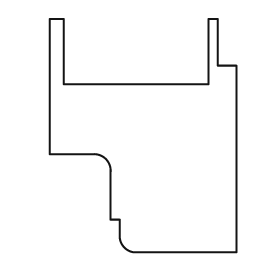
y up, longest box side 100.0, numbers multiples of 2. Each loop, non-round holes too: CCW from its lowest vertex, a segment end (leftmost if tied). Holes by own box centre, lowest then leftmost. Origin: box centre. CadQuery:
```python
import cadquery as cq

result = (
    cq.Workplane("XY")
    .moveTo(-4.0, -50.0)
    .lineTo(40.0, -50.0)
    .lineTo(40.0, 30.0)
    .lineTo(32.0, 30.0)
    .lineTo(32.0, 50.0)
    .lineTo(28.0, 50.0)
    .lineTo(28.0, 22.0)
    .lineTo(-34.0, 22.0)
    .lineTo(-34.0, 50.0)
    .lineTo(-40.0, 50.0)
    .lineTo(-40.0, -8.0)
    .lineTo(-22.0, -8.0)
    .threePointArc((-16.0, -10.0), (-14.0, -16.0))
    .lineTo(-14.0, -36.0)
    .lineTo(-10.0, -36.0)
    .lineTo(-10.0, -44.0)
    .threePointArc((-8.0, -48.0), (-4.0, -50.0))
    .close()
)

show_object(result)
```